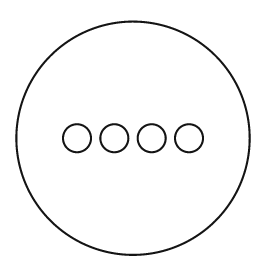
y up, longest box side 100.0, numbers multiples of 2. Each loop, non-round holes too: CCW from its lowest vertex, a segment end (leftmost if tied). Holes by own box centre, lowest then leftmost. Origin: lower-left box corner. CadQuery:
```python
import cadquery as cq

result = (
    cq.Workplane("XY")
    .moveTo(50.0, 50.0)
    .circle(50.0)
    .moveTo(26.0, 50.0)
    .circle(6.0)
    .moveTo(42.0, 50.0)
    .circle(6.0)
    .moveTo(58.0, 50.0)
    .circle(6.0)
    .moveTo(74.0, 50.0)
    .circle(6.0)
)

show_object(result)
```